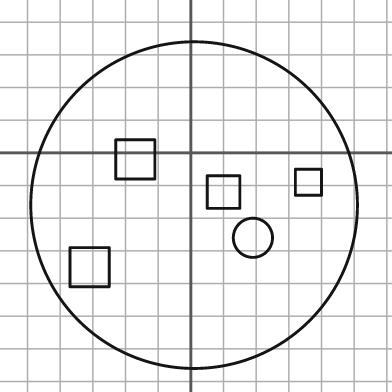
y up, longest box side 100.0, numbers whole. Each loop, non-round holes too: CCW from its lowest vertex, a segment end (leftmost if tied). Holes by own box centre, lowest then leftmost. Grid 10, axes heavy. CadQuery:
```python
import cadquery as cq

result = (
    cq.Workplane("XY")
    .moveTo(1.0, -16.0)
    .circle(50.0)
    .moveTo(-37.0, -41.0)
    .lineTo(-25.0, -41.0)
    .lineTo(-25.0, -29.0)
    .lineTo(-37.0, -29.0)
    .close()
    .moveTo(19.0, -26.0)
    .circle(6.0)
    .moveTo(5.0, -17.0)
    .lineTo(15.0, -17.0)
    .lineTo(15.0, -7.0)
    .lineTo(5.0, -7.0)
    .close()
    .moveTo(32.0, -13.0)
    .lineTo(40.0, -13.0)
    .lineTo(40.0, -5.0)
    .lineTo(32.0, -5.0)
    .close()
    .moveTo(-23.0, -8.0)
    .lineTo(-11.0, -8.0)
    .lineTo(-11.0, 4.0)
    .lineTo(-23.0, 4.0)
    .close()
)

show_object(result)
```